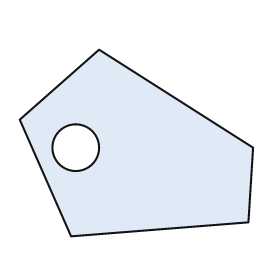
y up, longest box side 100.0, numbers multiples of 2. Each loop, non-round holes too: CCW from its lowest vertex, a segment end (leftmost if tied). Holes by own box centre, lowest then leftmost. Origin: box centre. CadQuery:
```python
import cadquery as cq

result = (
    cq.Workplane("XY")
    .moveTo(-28.0, -40.0)
    .lineTo(48.0, -34.0)
    .lineTo(50.0, -2.0)
    .lineTo(-16.0, 40.0)
    .lineTo(-50.0, 10.0)
    .close()
    .moveTo(-26.0, -2.0)
    .circle(10.0)
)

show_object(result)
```